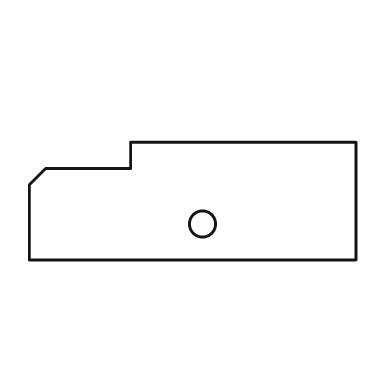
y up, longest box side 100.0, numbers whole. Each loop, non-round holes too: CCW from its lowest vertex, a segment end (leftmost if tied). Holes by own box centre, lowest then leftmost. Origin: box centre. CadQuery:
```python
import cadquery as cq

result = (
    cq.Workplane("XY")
    .moveTo(-50.0, -18.0)
    .lineTo(50.0, -18.0)
    .lineTo(50.0, 18.0)
    .lineTo(-19.0, 18.0)
    .lineTo(-19.0, 10.0)
    .lineTo(-45.0, 10.0)
    .lineTo(-50.0, 5.0)
    .close()
    .moveTo(3.0, -7.0)
    .circle(4.0)
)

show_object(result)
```